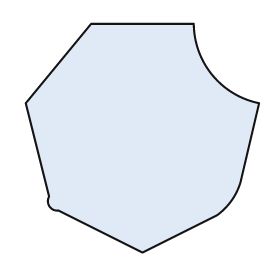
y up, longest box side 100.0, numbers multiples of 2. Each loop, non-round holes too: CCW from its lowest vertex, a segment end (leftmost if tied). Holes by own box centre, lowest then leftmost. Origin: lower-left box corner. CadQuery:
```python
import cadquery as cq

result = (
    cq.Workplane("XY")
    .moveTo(50.0, 0.0)
    .lineTo(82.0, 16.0)
    .threePointArc((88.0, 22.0), (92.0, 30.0))
    .lineTo(100.0, 64.0)
    .threePointArc((80.0, 76.0), (72.0, 98.0))
    .lineTo(28.0, 98.0)
    .lineTo(0.0, 64.0)
    .lineTo(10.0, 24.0)
    .threePointArc((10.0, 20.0), (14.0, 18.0))
    .close()
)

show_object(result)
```